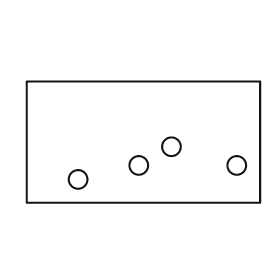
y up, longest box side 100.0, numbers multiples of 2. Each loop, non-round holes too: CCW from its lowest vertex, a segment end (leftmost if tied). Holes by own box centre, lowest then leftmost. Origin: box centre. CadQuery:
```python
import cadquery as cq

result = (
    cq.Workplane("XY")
    .moveTo(-50.0, -26.0)
    .lineTo(50.0, -26.0)
    .lineTo(50.0, 26.0)
    .lineTo(-50.0, 26.0)
    .close()
    .moveTo(-28.0, -16.0)
    .circle(4.0)
    .moveTo(-2.0, -10.0)
    .circle(4.0)
    .moveTo(40.0, -10.0)
    .circle(4.0)
    .moveTo(12.0, -2.0)
    .circle(4.0)
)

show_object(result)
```